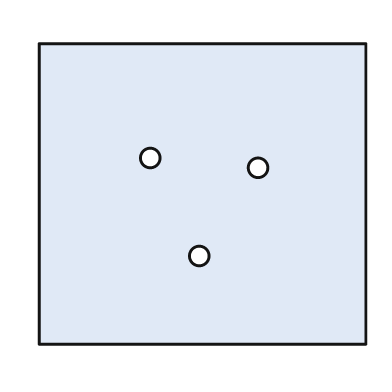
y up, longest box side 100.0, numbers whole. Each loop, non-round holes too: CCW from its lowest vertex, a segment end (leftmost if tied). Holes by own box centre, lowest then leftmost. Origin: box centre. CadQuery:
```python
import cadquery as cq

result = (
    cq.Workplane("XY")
    .moveTo(-50.0, -46.0)
    .lineTo(50.0, -46.0)
    .lineTo(50.0, 46.0)
    .lineTo(-50.0, 46.0)
    .close()
    .moveTo(-1.0, -19.0)
    .circle(3.0)
    .moveTo(17.0, 8.0)
    .circle(3.0)
    .moveTo(-16.0, 11.0)
    .circle(3.0)
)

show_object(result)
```